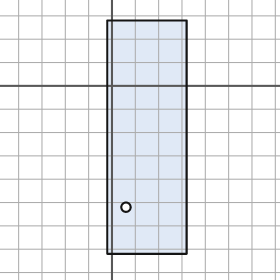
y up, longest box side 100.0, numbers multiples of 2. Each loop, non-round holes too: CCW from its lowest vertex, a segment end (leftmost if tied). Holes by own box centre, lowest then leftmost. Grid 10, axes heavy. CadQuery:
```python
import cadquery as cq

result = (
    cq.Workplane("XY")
    .moveTo(-2.0, -72.0)
    .lineTo(32.0, -72.0)
    .lineTo(32.0, 28.0)
    .lineTo(-2.0, 28.0)
    .close()
    .moveTo(6.0, -52.0)
    .circle(2.0)
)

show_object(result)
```